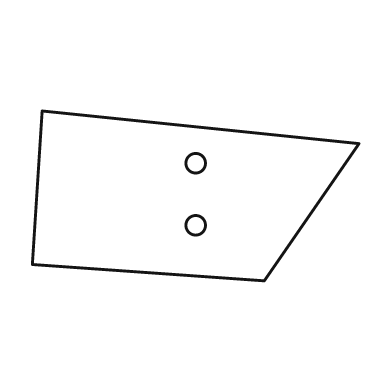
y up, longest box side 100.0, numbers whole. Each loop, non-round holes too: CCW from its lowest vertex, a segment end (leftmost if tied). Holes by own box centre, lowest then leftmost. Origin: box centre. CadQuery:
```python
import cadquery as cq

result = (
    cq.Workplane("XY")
    .moveTo(21.0, -26.0)
    .lineTo(50.0, 16.0)
    .lineTo(-47.0, 26.0)
    .lineTo(-50.0, -21.0)
    .close()
    .moveTo(0.0, -9.0)
    .circle(3.0)
    .moveTo(0.0, 10.0)
    .circle(3.0)
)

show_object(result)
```